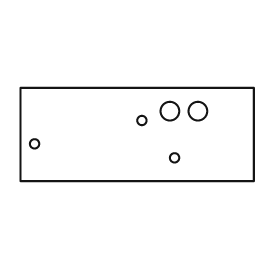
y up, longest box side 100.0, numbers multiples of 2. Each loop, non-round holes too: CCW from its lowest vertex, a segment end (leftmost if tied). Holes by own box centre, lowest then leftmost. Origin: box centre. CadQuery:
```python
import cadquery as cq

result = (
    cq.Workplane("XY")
    .moveTo(-50.0, -20.0)
    .lineTo(50.0, -20.0)
    .lineTo(50.0, 20.0)
    .lineTo(-50.0, 20.0)
    .close()
    .moveTo(16.0, -10.0)
    .circle(2.0)
    .moveTo(-44.0, -4.0)
    .circle(2.0)
    .moveTo(2.0, 6.0)
    .circle(2.0)
    .moveTo(14.0, 10.0)
    .circle(4.0)
    .moveTo(26.0, 10.0)
    .circle(4.0)
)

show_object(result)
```